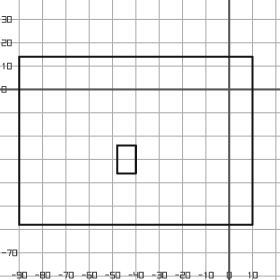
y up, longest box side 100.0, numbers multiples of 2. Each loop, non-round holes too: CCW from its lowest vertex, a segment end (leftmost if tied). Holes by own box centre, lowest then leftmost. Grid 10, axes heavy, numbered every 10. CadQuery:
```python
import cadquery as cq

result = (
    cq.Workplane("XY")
    .moveTo(-90.0, -58.0)
    .lineTo(10.0, -58.0)
    .lineTo(10.0, 14.0)
    .lineTo(-90.0, 14.0)
    .close()
    .moveTo(-48.0, -36.0)
    .lineTo(-40.0, -36.0)
    .lineTo(-40.0, -24.0)
    .lineTo(-48.0, -24.0)
    .close()
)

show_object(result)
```